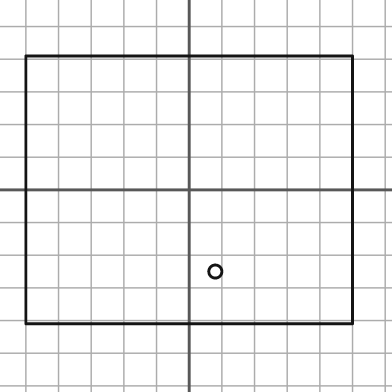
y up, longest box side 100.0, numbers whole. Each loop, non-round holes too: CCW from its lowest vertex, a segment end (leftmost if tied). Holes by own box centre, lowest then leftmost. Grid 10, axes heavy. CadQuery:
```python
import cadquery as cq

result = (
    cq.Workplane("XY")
    .moveTo(-50.0, -41.0)
    .lineTo(50.0, -41.0)
    .lineTo(50.0, 41.0)
    .lineTo(-50.0, 41.0)
    .close()
    .moveTo(8.0, -25.0)
    .circle(2.0)
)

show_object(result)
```